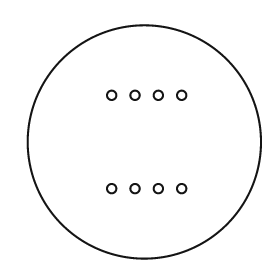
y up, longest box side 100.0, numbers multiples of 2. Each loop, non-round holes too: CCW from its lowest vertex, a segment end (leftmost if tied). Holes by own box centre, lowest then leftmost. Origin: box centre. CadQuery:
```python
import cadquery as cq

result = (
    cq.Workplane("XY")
    .moveTo(0.0, 0.0)
    .circle(50.0)
    .moveTo(-14.0, -20.0)
    .circle(2.0)
    .moveTo(-4.0, -20.0)
    .circle(2.0)
    .moveTo(6.0, -20.0)
    .circle(2.0)
    .moveTo(16.0, -20.0)
    .circle(2.0)
    .moveTo(-14.0, 20.0)
    .circle(2.0)
    .moveTo(-4.0, 20.0)
    .circle(2.0)
    .moveTo(6.0, 20.0)
    .circle(2.0)
    .moveTo(16.0, 20.0)
    .circle(2.0)
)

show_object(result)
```